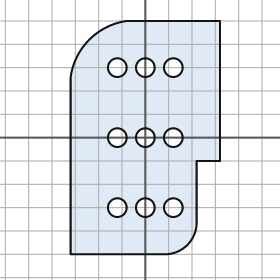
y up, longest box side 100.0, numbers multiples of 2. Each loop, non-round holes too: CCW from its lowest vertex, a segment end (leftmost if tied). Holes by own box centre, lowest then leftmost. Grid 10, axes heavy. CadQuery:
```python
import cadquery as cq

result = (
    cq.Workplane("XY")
    .moveTo(-32.0, -50.0)
    .lineTo(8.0, -50.0)
    .threePointArc((18.0, -46.0), (22.0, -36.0))
    .lineTo(22.0, -10.0)
    .lineTo(32.0, -10.0)
    .lineTo(32.0, 50.0)
    .lineTo(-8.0, 50.0)
    .threePointArc((-24.0, 42.0), (-32.0, 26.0))
    .close()
    .moveTo(-12.0, -30.0)
    .circle(4.0)
    .moveTo(0.0, -30.0)
    .circle(4.0)
    .moveTo(12.0, -30.0)
    .circle(4.0)
    .moveTo(-12.0, 0.0)
    .circle(4.0)
    .moveTo(0.0, 0.0)
    .circle(4.0)
    .moveTo(12.0, 0.0)
    .circle(4.0)
    .moveTo(-12.0, 30.0)
    .circle(4.0)
    .moveTo(0.0, 30.0)
    .circle(4.0)
    .moveTo(12.0, 30.0)
    .circle(4.0)
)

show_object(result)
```